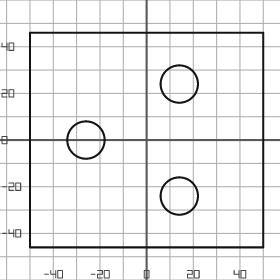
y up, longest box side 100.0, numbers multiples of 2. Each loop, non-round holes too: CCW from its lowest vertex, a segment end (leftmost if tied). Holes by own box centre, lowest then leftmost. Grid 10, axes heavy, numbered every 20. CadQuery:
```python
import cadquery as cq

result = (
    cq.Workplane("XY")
    .moveTo(-50.0, -46.0)
    .lineTo(50.0, -46.0)
    .lineTo(50.0, 46.0)
    .lineTo(-50.0, 46.0)
    .close()
    .moveTo(14.0, -24.0)
    .circle(8.0)
    .moveTo(-26.0, 0.0)
    .circle(8.0)
    .moveTo(14.0, 24.0)
    .circle(8.0)
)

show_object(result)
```